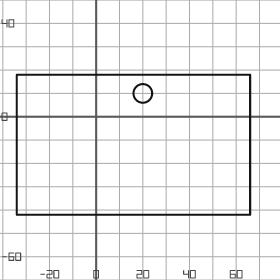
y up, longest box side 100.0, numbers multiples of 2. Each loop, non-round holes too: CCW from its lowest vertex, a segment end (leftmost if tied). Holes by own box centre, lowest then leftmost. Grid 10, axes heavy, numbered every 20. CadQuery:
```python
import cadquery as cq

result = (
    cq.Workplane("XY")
    .moveTo(-34.0, -42.0)
    .lineTo(66.0, -42.0)
    .lineTo(66.0, 18.0)
    .lineTo(-34.0, 18.0)
    .close()
    .moveTo(20.0, 10.0)
    .circle(4.0)
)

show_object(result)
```